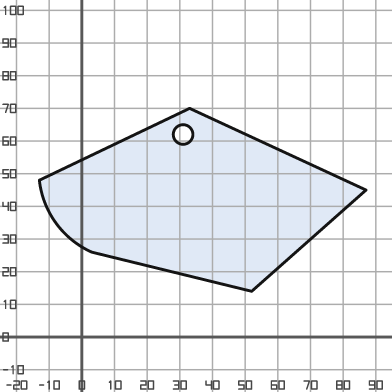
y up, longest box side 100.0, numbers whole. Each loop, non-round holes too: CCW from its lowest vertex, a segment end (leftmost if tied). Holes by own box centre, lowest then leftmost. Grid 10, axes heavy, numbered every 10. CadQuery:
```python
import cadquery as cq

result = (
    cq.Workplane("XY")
    .moveTo(52.0, 14.0)
    .lineTo(87.0, 45.0)
    .lineTo(33.0, 70.0)
    .lineTo(-13.0, 48.0)
    .threePointArc((-8.0, 35.0), (3.0, 26.0))
    .close()
    .moveTo(31.0, 62.0)
    .circle(3.0)
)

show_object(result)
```